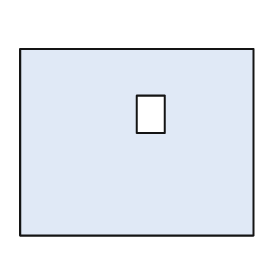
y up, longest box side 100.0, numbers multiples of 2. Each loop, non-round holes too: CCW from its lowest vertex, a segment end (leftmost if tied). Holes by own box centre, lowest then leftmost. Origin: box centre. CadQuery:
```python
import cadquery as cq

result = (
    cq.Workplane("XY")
    .moveTo(-50.0, -40.0)
    .lineTo(50.0, -40.0)
    .lineTo(50.0, 40.0)
    .lineTo(-50.0, 40.0)
    .close()
    .moveTo(0.0, 4.0)
    .lineTo(12.0, 4.0)
    .lineTo(12.0, 20.0)
    .lineTo(0.0, 20.0)
    .close()
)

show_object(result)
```